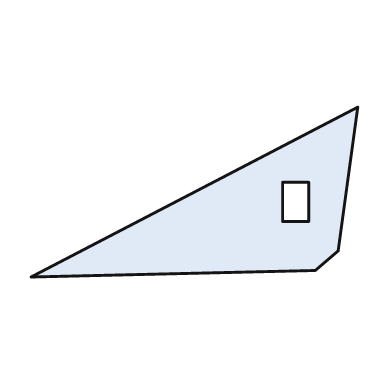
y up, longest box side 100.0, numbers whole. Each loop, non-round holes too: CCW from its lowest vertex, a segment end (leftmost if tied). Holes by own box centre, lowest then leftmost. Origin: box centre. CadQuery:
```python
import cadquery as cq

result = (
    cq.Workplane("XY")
    .moveTo(-50.0, -26.0)
    .lineTo(37.0, -24.0)
    .lineTo(44.0, -18.0)
    .lineTo(50.0, 26.0)
    .close()
    .moveTo(27.0, -9.0)
    .lineTo(35.0, -9.0)
    .lineTo(35.0, 3.0)
    .lineTo(27.0, 3.0)
    .close()
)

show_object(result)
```